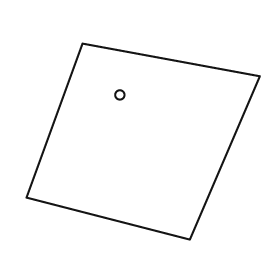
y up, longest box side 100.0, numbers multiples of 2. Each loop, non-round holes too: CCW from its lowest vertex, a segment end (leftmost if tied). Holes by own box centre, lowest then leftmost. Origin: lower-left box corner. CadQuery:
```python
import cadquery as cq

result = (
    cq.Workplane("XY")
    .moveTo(70.0, 0.0)
    .lineTo(100.0, 70.0)
    .lineTo(24.0, 84.0)
    .lineTo(0.0, 18.0)
    .close()
    .moveTo(40.0, 62.0)
    .circle(2.0)
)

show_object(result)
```